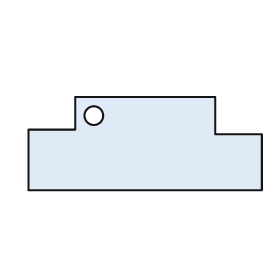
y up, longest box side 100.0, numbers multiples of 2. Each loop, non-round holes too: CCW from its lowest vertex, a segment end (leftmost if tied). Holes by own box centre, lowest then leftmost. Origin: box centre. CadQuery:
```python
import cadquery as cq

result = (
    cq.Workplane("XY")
    .moveTo(-50.0, -20.0)
    .lineTo(50.0, -20.0)
    .lineTo(50.0, 4.0)
    .lineTo(30.0, 4.0)
    .lineTo(30.0, 20.0)
    .lineTo(-30.0, 20.0)
    .lineTo(-30.0, 6.0)
    .lineTo(-50.0, 6.0)
    .close()
    .moveTo(-22.0, 12.0)
    .circle(4.0)
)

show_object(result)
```